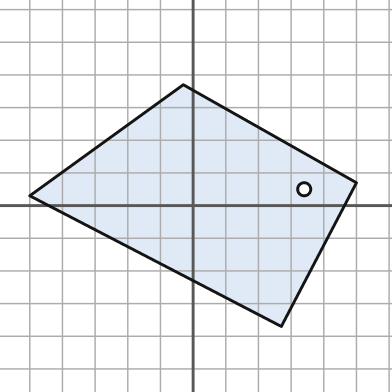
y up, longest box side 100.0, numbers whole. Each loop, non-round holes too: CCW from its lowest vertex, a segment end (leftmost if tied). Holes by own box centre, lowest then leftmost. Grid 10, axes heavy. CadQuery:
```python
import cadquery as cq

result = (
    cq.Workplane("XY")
    .moveTo(27.0, -37.0)
    .lineTo(50.0, 7.0)
    .lineTo(-3.0, 37.0)
    .lineTo(-50.0, 3.0)
    .close()
    .moveTo(34.0, 5.0)
    .circle(2.0)
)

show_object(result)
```